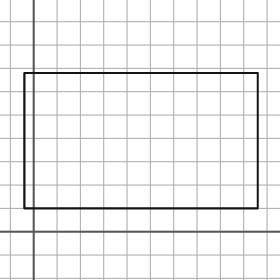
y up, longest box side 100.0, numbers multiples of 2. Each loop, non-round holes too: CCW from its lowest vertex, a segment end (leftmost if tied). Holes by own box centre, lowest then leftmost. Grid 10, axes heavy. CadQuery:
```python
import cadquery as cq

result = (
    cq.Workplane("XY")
    .moveTo(-4.0, 10.0)
    .lineTo(96.0, 10.0)
    .lineTo(96.0, 68.0)
    .lineTo(-4.0, 68.0)
    .close()
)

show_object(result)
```